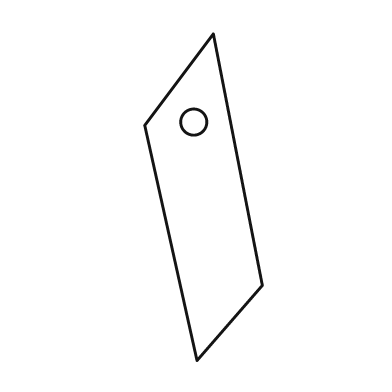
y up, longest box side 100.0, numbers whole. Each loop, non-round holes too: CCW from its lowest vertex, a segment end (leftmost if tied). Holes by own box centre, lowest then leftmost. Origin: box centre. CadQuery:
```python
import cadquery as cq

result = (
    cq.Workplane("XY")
    .moveTo(-2.0, -50.0)
    .lineTo(18.0, -27.0)
    .lineTo(3.0, 50.0)
    .lineTo(-18.0, 22.0)
    .close()
    .moveTo(-3.0, 23.0)
    .circle(4.0)
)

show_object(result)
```